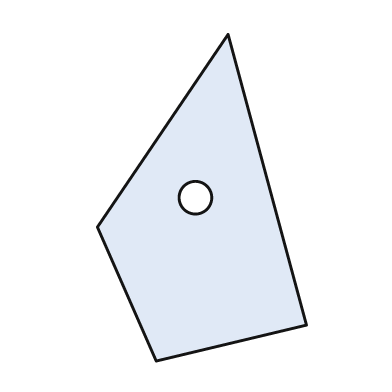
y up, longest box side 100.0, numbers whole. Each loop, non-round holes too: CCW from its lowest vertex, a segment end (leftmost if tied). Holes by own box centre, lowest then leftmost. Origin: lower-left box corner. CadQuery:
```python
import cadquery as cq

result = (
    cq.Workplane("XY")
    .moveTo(18.0, 0.0)
    .lineTo(64.0, 11.0)
    .lineTo(40.0, 100.0)
    .lineTo(0.0, 41.0)
    .close()
    .moveTo(30.0, 50.0)
    .circle(5.0)
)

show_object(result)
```